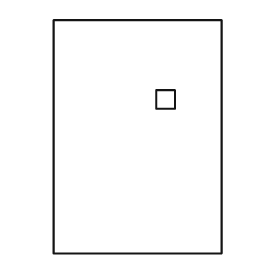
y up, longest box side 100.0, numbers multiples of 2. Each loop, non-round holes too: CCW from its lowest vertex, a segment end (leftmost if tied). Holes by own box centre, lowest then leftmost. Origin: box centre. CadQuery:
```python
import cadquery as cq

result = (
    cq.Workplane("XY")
    .moveTo(-36.0, -50.0)
    .lineTo(36.0, -50.0)
    .lineTo(36.0, 50.0)
    .lineTo(-36.0, 50.0)
    .close()
    .moveTo(8.0, 12.0)
    .lineTo(16.0, 12.0)
    .lineTo(16.0, 20.0)
    .lineTo(8.0, 20.0)
    .close()
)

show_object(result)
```